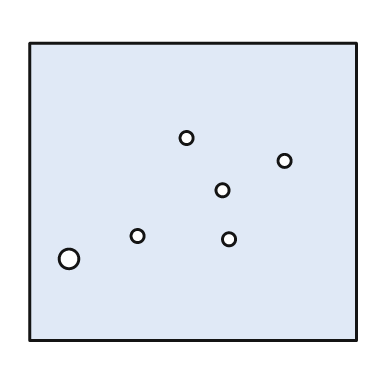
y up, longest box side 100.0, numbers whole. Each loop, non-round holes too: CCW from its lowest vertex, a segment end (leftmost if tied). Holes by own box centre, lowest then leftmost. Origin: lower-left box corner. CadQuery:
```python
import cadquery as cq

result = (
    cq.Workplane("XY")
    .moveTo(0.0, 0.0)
    .lineTo(100.0, 0.0)
    .lineTo(100.0, 91.0)
    .lineTo(0.0, 91.0)
    .close()
    .moveTo(12.0, 25.0)
    .circle(3.0)
    .moveTo(61.0, 31.0)
    .circle(2.0)
    .moveTo(33.0, 32.0)
    .circle(2.0)
    .moveTo(59.0, 46.0)
    .circle(2.0)
    .moveTo(78.0, 55.0)
    .circle(2.0)
    .moveTo(48.0, 62.0)
    .circle(2.0)
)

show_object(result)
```